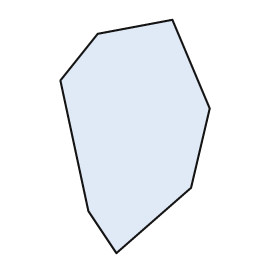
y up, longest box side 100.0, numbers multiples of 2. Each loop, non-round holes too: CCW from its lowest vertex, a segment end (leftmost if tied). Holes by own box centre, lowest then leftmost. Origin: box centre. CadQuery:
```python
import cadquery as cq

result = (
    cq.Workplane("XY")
    .moveTo(-8.0, -50.0)
    .lineTo(24.0, -22.0)
    .lineTo(32.0, 12.0)
    .lineTo(16.0, 50.0)
    .lineTo(-16.0, 44.0)
    .lineTo(-32.0, 24.0)
    .lineTo(-20.0, -32.0)
    .close()
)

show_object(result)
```